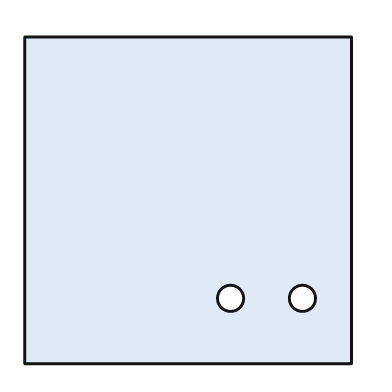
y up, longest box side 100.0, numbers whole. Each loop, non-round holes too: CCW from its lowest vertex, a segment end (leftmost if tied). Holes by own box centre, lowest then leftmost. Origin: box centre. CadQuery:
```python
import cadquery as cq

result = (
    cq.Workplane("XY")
    .moveTo(-50.0, -50.0)
    .lineTo(50.0, -50.0)
    .lineTo(50.0, 50.0)
    .lineTo(-50.0, 50.0)
    .close()
    .moveTo(13.0, -30.0)
    .circle(4.0)
    .moveTo(35.0, -30.0)
    .circle(4.0)
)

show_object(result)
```